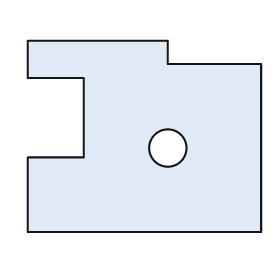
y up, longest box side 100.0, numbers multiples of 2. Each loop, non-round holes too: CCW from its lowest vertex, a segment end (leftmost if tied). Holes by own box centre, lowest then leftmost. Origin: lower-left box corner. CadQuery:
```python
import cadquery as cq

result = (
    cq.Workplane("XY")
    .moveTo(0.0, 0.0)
    .lineTo(100.0, 0.0)
    .lineTo(100.0, 72.0)
    .lineTo(60.0, 72.0)
    .lineTo(60.0, 82.0)
    .lineTo(0.0, 82.0)
    .lineTo(0.0, 66.0)
    .lineTo(24.0, 66.0)
    .lineTo(24.0, 32.0)
    .lineTo(0.0, 32.0)
    .close()
    .moveTo(60.0, 36.0)
    .circle(8.0)
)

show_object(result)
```